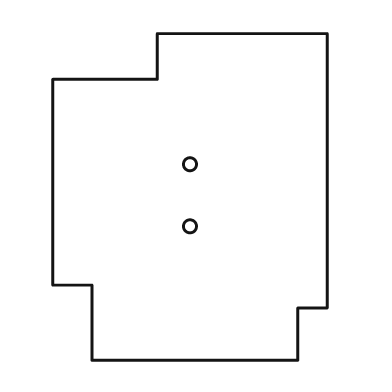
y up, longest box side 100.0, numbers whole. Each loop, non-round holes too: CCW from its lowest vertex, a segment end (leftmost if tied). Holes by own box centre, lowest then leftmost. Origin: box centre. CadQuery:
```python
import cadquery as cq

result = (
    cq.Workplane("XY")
    .moveTo(-30.0, -50.0)
    .lineTo(33.0, -50.0)
    .lineTo(33.0, -34.0)
    .lineTo(42.0, -34.0)
    .lineTo(42.0, 50.0)
    .lineTo(-10.0, 50.0)
    .lineTo(-10.0, 36.0)
    .lineTo(-42.0, 36.0)
    .lineTo(-42.0, -27.0)
    .lineTo(-30.0, -27.0)
    .close()
    .moveTo(0.0, -9.0)
    .circle(2.0)
    .moveTo(0.0, 10.0)
    .circle(2.0)
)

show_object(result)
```